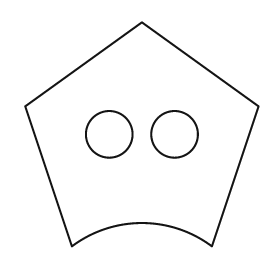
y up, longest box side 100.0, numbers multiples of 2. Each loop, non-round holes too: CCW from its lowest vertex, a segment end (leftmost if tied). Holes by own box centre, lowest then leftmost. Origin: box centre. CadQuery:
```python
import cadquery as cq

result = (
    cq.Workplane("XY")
    .moveTo(-30.0, -48.0)
    .threePointArc((0.0, -38.0), (30.0, -48.0))
    .lineTo(50.0, 12.0)
    .lineTo(0.0, 48.0)
    .lineTo(-50.0, 12.0)
    .close()
    .moveTo(-14.0, 0.0)
    .circle(10.0)
    .moveTo(14.0, 0.0)
    .circle(10.0)
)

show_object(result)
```